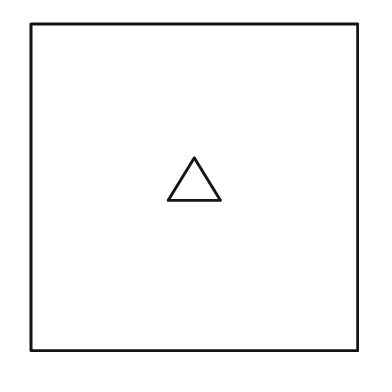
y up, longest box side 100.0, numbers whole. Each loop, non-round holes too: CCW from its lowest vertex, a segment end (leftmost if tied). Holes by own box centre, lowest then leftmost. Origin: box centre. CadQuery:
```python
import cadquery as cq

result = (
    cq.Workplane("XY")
    .moveTo(-50.0, -50.0)
    .lineTo(50.0, -50.0)
    .lineTo(50.0, 50.0)
    .lineTo(-50.0, 50.0)
    .close()
    .moveTo(-8.0, -4.0)
    .lineTo(8.0, -4.0)
    .lineTo(0.0, 9.0)
    .close()
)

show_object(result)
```